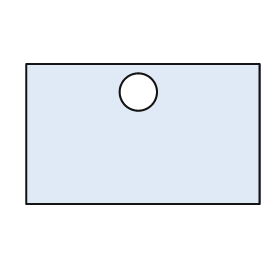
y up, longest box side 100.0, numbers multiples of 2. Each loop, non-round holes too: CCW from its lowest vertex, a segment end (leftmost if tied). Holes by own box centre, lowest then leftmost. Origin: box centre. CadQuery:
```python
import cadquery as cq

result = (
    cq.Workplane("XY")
    .moveTo(-50.0, -30.0)
    .lineTo(50.0, -30.0)
    .lineTo(50.0, 30.0)
    .lineTo(-50.0, 30.0)
    .close()
    .moveTo(-2.0, 18.0)
    .circle(8.0)
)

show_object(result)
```